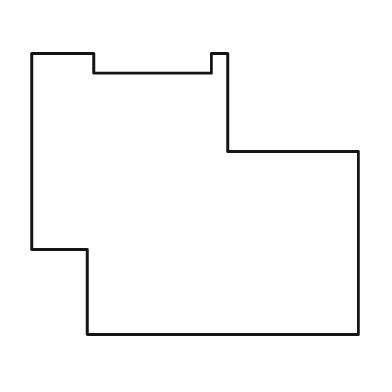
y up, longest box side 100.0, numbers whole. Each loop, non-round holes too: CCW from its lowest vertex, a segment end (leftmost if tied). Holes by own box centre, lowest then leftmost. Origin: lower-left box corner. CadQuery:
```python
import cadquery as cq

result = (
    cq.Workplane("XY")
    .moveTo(17.0, 0.0)
    .lineTo(100.0, 0.0)
    .lineTo(100.0, 56.0)
    .lineTo(60.0, 56.0)
    .lineTo(60.0, 86.0)
    .lineTo(55.0, 86.0)
    .lineTo(55.0, 80.0)
    .lineTo(19.0, 80.0)
    .lineTo(19.0, 86.0)
    .lineTo(0.0, 86.0)
    .lineTo(0.0, 26.0)
    .lineTo(17.0, 26.0)
    .close()
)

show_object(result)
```